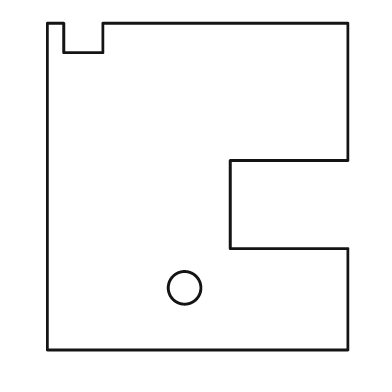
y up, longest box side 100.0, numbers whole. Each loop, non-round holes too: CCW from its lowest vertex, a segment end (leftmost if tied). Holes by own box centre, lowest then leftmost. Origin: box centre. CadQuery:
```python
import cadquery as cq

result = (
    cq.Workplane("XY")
    .moveTo(-46.0, -50.0)
    .lineTo(46.0, -50.0)
    .lineTo(46.0, -19.0)
    .lineTo(10.0, -19.0)
    .lineTo(10.0, 8.0)
    .lineTo(46.0, 8.0)
    .lineTo(46.0, 50.0)
    .lineTo(-29.0, 50.0)
    .lineTo(-29.0, 41.0)
    .lineTo(-41.0, 41.0)
    .lineTo(-41.0, 50.0)
    .lineTo(-46.0, 50.0)
    .close()
    .moveTo(-4.0, -31.0)
    .circle(5.0)
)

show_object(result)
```